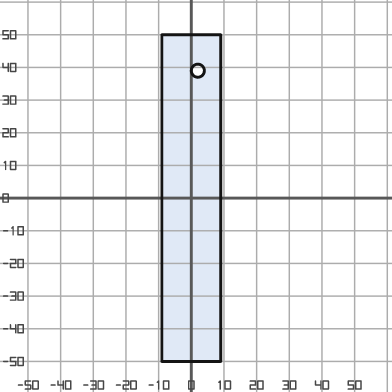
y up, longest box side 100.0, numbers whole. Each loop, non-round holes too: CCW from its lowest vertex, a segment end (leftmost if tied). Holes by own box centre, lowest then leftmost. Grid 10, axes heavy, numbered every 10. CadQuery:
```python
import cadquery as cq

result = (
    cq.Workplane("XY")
    .moveTo(-9.0, -50.0)
    .lineTo(9.0, -50.0)
    .lineTo(9.0, 50.0)
    .lineTo(-9.0, 50.0)
    .close()
    .moveTo(2.0, 39.0)
    .circle(2.0)
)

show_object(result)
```